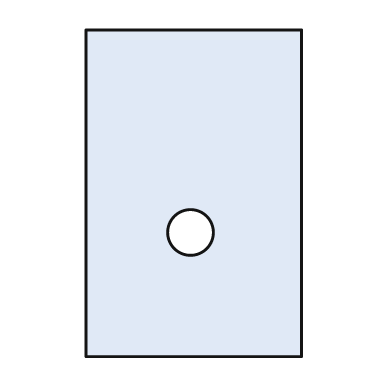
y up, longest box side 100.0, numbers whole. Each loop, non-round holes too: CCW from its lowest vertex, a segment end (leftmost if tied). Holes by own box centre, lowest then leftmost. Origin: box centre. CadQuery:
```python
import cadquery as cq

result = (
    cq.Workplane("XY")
    .moveTo(-33.0, -50.0)
    .lineTo(33.0, -50.0)
    .lineTo(33.0, 50.0)
    .lineTo(-33.0, 50.0)
    .close()
    .moveTo(-1.0, -12.0)
    .circle(7.0)
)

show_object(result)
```